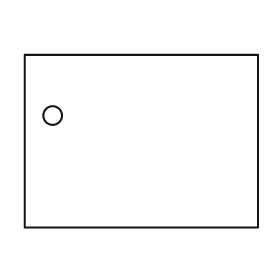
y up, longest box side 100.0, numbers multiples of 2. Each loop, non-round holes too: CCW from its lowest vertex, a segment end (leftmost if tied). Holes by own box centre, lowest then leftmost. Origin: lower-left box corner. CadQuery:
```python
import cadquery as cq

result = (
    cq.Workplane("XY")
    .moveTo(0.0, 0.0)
    .lineTo(100.0, 0.0)
    .lineTo(100.0, 74.0)
    .lineTo(0.0, 74.0)
    .close()
    .moveTo(12.0, 48.0)
    .circle(4.0)
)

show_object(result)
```